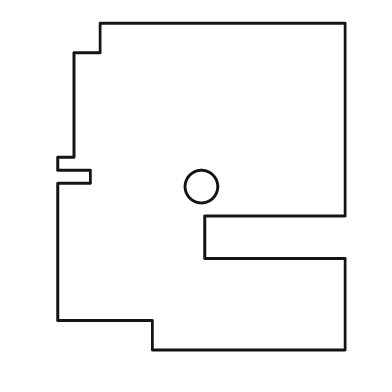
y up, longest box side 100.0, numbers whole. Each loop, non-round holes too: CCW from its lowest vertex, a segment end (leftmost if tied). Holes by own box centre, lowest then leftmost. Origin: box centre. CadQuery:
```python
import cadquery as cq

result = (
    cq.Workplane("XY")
    .moveTo(-15.0, -50.0)
    .lineTo(44.0, -50.0)
    .lineTo(44.0, -22.0)
    .lineTo(1.0, -22.0)
    .lineTo(1.0, -9.0)
    .lineTo(44.0, -9.0)
    .lineTo(44.0, 50.0)
    .lineTo(-31.0, 50.0)
    .lineTo(-31.0, 41.0)
    .lineTo(-39.0, 41.0)
    .lineTo(-39.0, 9.0)
    .lineTo(-44.0, 9.0)
    .lineTo(-44.0, 5.0)
    .lineTo(-34.0, 5.0)
    .lineTo(-34.0, 1.0)
    .lineTo(-44.0, 1.0)
    .lineTo(-44.0, -41.0)
    .lineTo(-15.0, -41.0)
    .close()
    .moveTo(0.0, 0.0)
    .circle(5.0)
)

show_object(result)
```